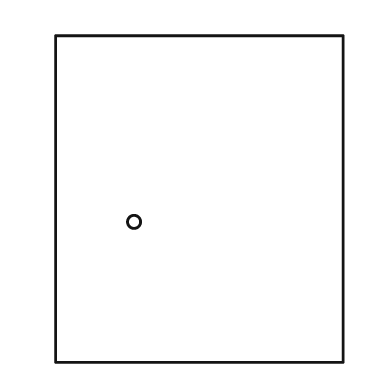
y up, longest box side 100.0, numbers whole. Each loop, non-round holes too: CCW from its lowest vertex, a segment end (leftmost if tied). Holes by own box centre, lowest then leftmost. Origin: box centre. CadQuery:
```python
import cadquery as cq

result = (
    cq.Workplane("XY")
    .moveTo(-44.0, -50.0)
    .lineTo(44.0, -50.0)
    .lineTo(44.0, 50.0)
    .lineTo(-44.0, 50.0)
    .close()
    .moveTo(-20.0, -7.0)
    .circle(2.0)
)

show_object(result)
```